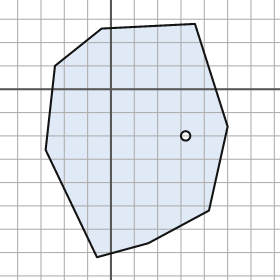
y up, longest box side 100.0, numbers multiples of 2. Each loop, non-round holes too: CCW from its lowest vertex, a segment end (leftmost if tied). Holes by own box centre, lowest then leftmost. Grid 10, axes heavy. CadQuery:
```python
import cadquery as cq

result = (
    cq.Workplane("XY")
    .moveTo(-6.0, -72.0)
    .lineTo(16.0, -66.0)
    .lineTo(42.0, -52.0)
    .lineTo(50.0, -16.0)
    .lineTo(36.0, 28.0)
    .lineTo(-4.0, 26.0)
    .lineTo(-24.0, 10.0)
    .lineTo(-28.0, -26.0)
    .close()
    .moveTo(32.0, -20.0)
    .circle(2.0)
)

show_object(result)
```